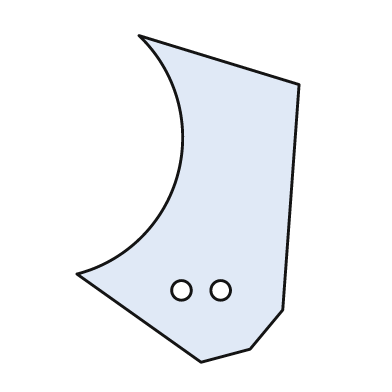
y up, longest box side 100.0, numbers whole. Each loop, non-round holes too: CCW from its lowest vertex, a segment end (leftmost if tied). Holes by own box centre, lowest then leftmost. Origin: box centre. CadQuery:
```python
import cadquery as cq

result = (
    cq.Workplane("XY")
    .moveTo(4.0, -50.0)
    .lineTo(19.0, -46.0)
    .lineTo(29.0, -34.0)
    .lineTo(34.0, 35.0)
    .lineTo(-15.0, 50.0)
    .threePointArc((-3.0, 8.0), (-34.0, -23.0))
    .close()
    .moveTo(-2.0, -28.0)
    .circle(3.0)
    .moveTo(10.0, -28.0)
    .circle(3.0)
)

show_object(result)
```